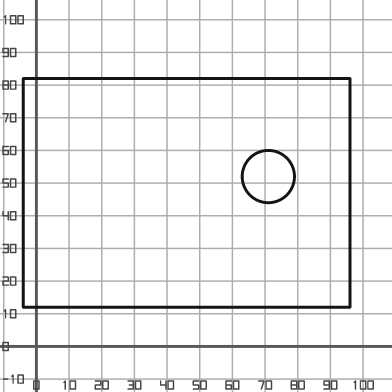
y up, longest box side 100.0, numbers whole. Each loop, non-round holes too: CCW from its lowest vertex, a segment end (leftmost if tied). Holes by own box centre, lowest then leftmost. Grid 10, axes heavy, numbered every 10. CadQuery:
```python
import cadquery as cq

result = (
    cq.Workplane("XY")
    .moveTo(-4.0, 12.0)
    .lineTo(96.0, 12.0)
    .lineTo(96.0, 82.0)
    .lineTo(-4.0, 82.0)
    .close()
    .moveTo(71.0, 52.0)
    .circle(8.0)
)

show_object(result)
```